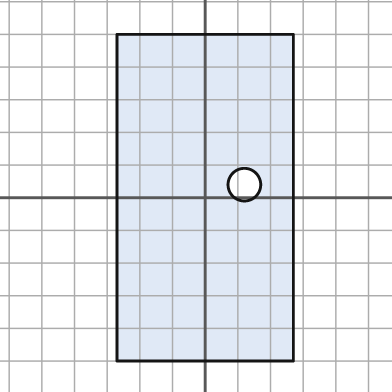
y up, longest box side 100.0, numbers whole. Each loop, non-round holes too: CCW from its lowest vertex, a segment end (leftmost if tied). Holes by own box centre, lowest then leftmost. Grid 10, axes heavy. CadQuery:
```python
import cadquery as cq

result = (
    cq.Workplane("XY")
    .moveTo(-27.0, -50.0)
    .lineTo(27.0, -50.0)
    .lineTo(27.0, 50.0)
    .lineTo(-27.0, 50.0)
    .close()
    .moveTo(12.0, 4.0)
    .circle(5.0)
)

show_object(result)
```